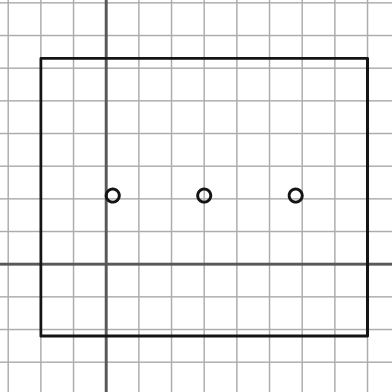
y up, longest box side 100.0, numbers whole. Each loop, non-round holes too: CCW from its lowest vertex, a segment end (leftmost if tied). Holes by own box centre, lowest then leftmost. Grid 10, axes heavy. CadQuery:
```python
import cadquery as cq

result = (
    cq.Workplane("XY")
    .moveTo(-20.0, -22.0)
    .lineTo(80.0, -22.0)
    .lineTo(80.0, 63.0)
    .lineTo(-20.0, 63.0)
    .close()
    .moveTo(2.0, 21.0)
    .circle(2.0)
    .moveTo(30.0, 21.0)
    .circle(2.0)
    .moveTo(58.0, 21.0)
    .circle(2.0)
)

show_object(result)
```